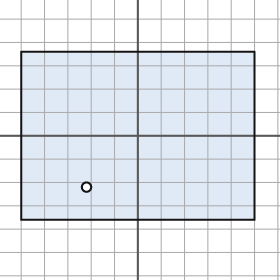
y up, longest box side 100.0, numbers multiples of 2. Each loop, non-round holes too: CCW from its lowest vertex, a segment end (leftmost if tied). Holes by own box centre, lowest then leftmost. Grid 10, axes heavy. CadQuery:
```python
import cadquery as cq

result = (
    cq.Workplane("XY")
    .moveTo(-50.0, -36.0)
    .lineTo(50.0, -36.0)
    .lineTo(50.0, 36.0)
    .lineTo(-50.0, 36.0)
    .close()
    .moveTo(-22.0, -22.0)
    .circle(2.0)
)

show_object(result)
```